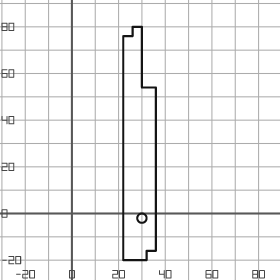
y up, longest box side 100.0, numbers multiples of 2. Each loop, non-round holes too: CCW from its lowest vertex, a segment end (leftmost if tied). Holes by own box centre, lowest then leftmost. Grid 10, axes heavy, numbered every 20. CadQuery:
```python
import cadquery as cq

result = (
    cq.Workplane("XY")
    .moveTo(22.0, -20.0)
    .lineTo(32.0, -20.0)
    .lineTo(32.0, -16.0)
    .lineTo(36.0, -16.0)
    .lineTo(36.0, 54.0)
    .lineTo(30.0, 54.0)
    .lineTo(30.0, 80.0)
    .lineTo(26.0, 80.0)
    .lineTo(26.0, 76.0)
    .lineTo(22.0, 76.0)
    .close()
    .moveTo(30.0, -2.0)
    .circle(2.0)
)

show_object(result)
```